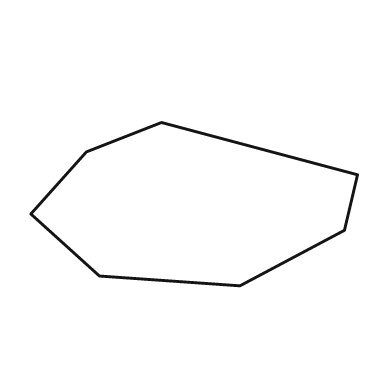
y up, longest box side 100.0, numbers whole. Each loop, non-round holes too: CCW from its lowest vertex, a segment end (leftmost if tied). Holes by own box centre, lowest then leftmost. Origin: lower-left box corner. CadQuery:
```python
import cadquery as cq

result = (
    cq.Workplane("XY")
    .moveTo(64.0, 0.0)
    .lineTo(96.0, 17.0)
    .lineTo(100.0, 34.0)
    .lineTo(40.0, 50.0)
    .lineTo(17.0, 41.0)
    .lineTo(0.0, 22.0)
    .lineTo(21.0, 3.0)
    .close()
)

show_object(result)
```